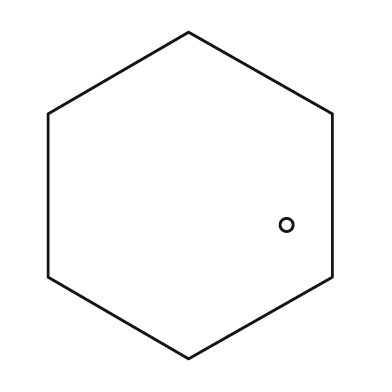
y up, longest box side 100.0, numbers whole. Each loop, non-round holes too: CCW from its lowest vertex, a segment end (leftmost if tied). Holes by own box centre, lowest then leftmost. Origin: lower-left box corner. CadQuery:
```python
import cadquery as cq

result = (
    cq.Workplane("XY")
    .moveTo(43.0, 0.0)
    .lineTo(87.0, 25.0)
    .lineTo(87.0, 75.0)
    .lineTo(43.0, 100.0)
    .lineTo(0.0, 75.0)
    .lineTo(0.0, 25.0)
    .close()
    .moveTo(73.0, 41.0)
    .circle(2.0)
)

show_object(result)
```